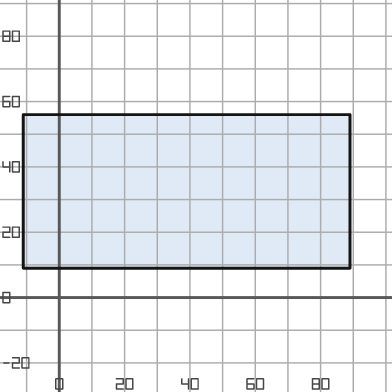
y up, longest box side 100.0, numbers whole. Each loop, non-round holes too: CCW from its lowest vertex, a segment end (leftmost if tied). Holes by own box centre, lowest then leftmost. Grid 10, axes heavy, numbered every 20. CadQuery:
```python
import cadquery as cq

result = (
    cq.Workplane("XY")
    .moveTo(-11.0, 9.0)
    .lineTo(89.0, 9.0)
    .lineTo(89.0, 56.0)
    .lineTo(-11.0, 56.0)
    .close()
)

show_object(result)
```